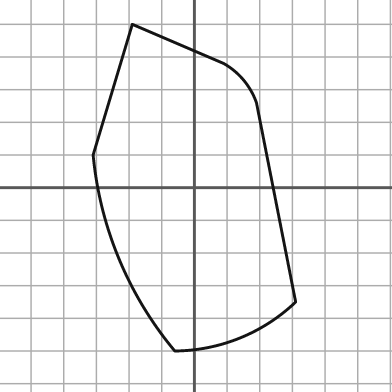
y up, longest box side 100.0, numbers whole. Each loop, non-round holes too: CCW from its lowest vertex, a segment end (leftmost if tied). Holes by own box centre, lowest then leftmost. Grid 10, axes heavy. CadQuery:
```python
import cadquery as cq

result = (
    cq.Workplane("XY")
    .moveTo(-6.0, -50.0)
    .threePointArc((14.0, -46.0), (31.0, -35.0))
    .lineTo(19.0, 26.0)
    .threePointArc((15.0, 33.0), (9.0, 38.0))
    .lineTo(-19.0, 50.0)
    .lineTo(-31.0, 10.0)
    .threePointArc((-23.0, -22.0), (-6.0, -50.0))
    .close()
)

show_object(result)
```